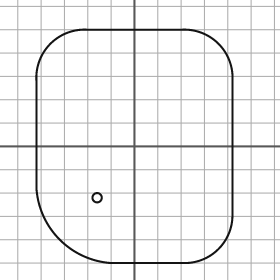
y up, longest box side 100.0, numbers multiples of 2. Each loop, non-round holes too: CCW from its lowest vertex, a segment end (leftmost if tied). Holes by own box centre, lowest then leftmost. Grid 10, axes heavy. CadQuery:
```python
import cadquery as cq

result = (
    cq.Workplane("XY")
    .moveTo(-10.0, -50.0)
    .lineTo(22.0, -50.0)
    .threePointArc((36.0, -44.0), (42.0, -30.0))
    .lineTo(42.0, 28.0)
    .threePointArc((36.0, 44.0), (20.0, 50.0))
    .lineTo(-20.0, 50.0)
    .threePointArc((-36.0, 44.0), (-42.0, 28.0))
    .lineTo(-42.0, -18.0)
    .threePointArc((-32.0, -40.0), (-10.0, -50.0))
    .close()
    .moveTo(-16.0, -22.0)
    .circle(2.0)
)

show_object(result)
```